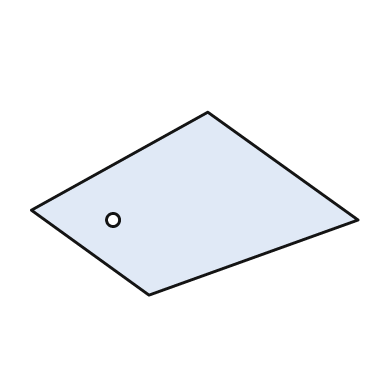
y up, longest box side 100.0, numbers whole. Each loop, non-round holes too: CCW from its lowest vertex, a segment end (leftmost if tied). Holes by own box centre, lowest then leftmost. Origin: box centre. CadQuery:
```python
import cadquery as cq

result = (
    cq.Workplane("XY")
    .moveTo(-14.0, -28.0)
    .lineTo(50.0, -5.0)
    .lineTo(4.0, 28.0)
    .lineTo(-50.0, -2.0)
    .close()
    .moveTo(-25.0, -5.0)
    .circle(2.0)
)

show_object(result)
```